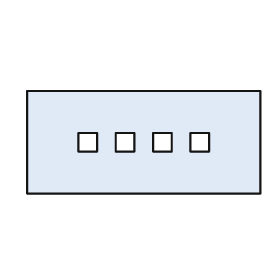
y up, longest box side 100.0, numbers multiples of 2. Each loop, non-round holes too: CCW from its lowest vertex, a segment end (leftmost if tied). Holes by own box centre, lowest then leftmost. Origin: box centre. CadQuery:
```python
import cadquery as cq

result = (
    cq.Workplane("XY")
    .moveTo(-50.0, -22.0)
    .lineTo(50.0, -22.0)
    .lineTo(50.0, 22.0)
    .lineTo(-50.0, 22.0)
    .close()
    .moveTo(-28.0, -4.0)
    .lineTo(-20.0, -4.0)
    .lineTo(-20.0, 4.0)
    .lineTo(-28.0, 4.0)
    .close()
    .moveTo(-12.0, -4.0)
    .lineTo(-4.0, -4.0)
    .lineTo(-4.0, 4.0)
    .lineTo(-12.0, 4.0)
    .close()
    .moveTo(4.0, -4.0)
    .lineTo(12.0, -4.0)
    .lineTo(12.0, 4.0)
    .lineTo(4.0, 4.0)
    .close()
    .moveTo(20.0, -4.0)
    .lineTo(28.0, -4.0)
    .lineTo(28.0, 4.0)
    .lineTo(20.0, 4.0)
    .close()
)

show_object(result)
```